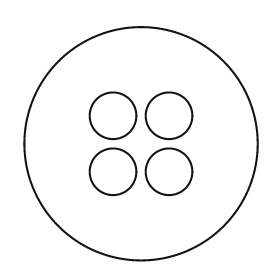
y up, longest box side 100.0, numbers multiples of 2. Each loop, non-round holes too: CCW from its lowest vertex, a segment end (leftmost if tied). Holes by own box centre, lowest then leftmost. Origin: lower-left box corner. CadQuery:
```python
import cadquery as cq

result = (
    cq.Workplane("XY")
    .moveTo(50.0, 50.0)
    .circle(50.0)
    .moveTo(38.0, 38.0)
    .circle(10.0)
    .moveTo(62.0, 38.0)
    .circle(10.0)
    .moveTo(38.0, 62.0)
    .circle(10.0)
    .moveTo(62.0, 62.0)
    .circle(10.0)
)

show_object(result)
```